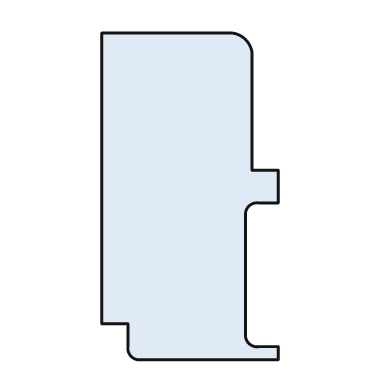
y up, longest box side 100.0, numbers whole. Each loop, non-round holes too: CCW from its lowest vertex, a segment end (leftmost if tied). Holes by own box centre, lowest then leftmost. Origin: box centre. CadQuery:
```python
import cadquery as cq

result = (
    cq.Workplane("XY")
    .moveTo(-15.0, -50.0)
    .lineTo(27.0, -50.0)
    .lineTo(27.0, -46.0)
    .lineTo(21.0, -46.0)
    .threePointArc((18.0, -45.0), (17.0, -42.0))
    .lineTo(17.0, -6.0)
    .threePointArc((18.0, -3.0), (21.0, -2.0))
    .lineTo(27.0, -2.0)
    .lineTo(27.0, 8.0)
    .lineTo(19.0, 8.0)
    .lineTo(19.0, 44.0)
    .threePointArc((17.0, 48.0), (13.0, 50.0))
    .lineTo(-27.0, 50.0)
    .lineTo(-27.0, -39.0)
    .lineTo(-19.0, -39.0)
    .lineTo(-19.0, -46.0)
    .threePointArc((-18.0, -49.0), (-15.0, -50.0))
    .close()
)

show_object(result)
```